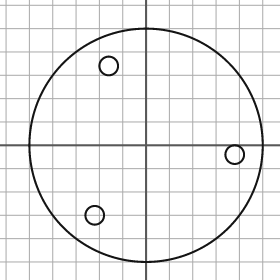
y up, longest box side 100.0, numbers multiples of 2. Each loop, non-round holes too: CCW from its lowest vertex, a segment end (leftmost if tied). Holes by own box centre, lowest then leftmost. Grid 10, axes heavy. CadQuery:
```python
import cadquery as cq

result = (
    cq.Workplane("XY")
    .moveTo(0.0, 0.0)
    .circle(50.0)
    .moveTo(-22.0, -30.0)
    .circle(4.0)
    .moveTo(38.0, -4.0)
    .circle(4.0)
    .moveTo(-16.0, 34.0)
    .circle(4.0)
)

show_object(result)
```